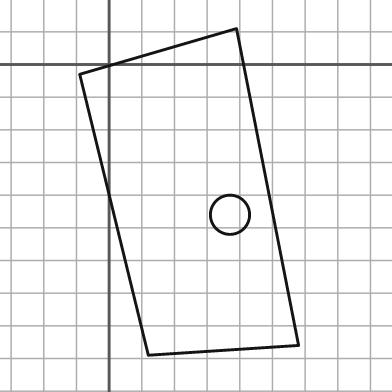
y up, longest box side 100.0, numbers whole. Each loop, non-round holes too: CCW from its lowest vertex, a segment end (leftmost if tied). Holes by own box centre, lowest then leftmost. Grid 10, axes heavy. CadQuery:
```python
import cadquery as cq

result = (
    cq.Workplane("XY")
    .moveTo(12.0, -89.0)
    .lineTo(58.0, -86.0)
    .lineTo(39.0, 11.0)
    .lineTo(-9.0, -3.0)
    .close()
    .moveTo(37.0, -46.0)
    .circle(6.0)
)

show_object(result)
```